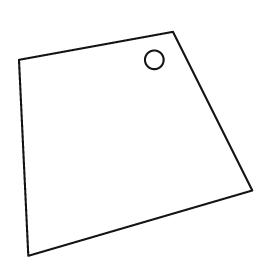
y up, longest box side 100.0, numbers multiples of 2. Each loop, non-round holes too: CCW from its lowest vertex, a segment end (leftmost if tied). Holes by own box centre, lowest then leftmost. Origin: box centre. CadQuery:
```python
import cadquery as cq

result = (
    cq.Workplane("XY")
    .moveTo(-46.0, -48.0)
    .lineTo(50.0, -20.0)
    .lineTo(16.0, 48.0)
    .lineTo(-50.0, 36.0)
    .close()
    .moveTo(8.0, 36.0)
    .circle(4.0)
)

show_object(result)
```